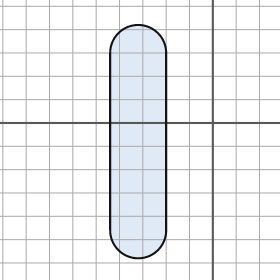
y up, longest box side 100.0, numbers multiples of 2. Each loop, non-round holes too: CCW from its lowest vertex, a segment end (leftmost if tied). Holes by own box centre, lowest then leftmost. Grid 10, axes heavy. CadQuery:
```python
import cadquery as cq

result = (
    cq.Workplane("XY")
    .moveTo(-44.0, -46.0)
    .threePointArc((-32.0, -58.0), (-20.0, -46.0))
    .lineTo(-20.0, 30.0)
    .threePointArc((-32.0, 42.0), (-44.0, 30.0))
    .close()
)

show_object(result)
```